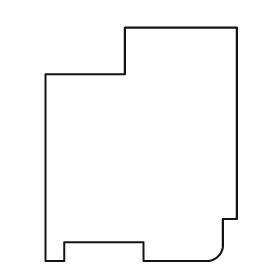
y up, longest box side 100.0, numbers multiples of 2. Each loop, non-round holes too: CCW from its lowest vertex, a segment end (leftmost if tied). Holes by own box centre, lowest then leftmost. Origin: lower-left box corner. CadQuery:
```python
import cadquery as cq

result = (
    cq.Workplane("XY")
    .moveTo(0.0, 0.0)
    .lineTo(8.0, 0.0)
    .lineTo(8.0, 8.0)
    .lineTo(42.0, 8.0)
    .lineTo(42.0, 0.0)
    .lineTo(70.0, 0.0)
    .threePointArc((74.0, 2.0), (76.0, 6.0))
    .lineTo(76.0, 18.0)
    .lineTo(82.0, 18.0)
    .lineTo(82.0, 100.0)
    .lineTo(34.0, 100.0)
    .lineTo(34.0, 80.0)
    .lineTo(0.0, 80.0)
    .close()
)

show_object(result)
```